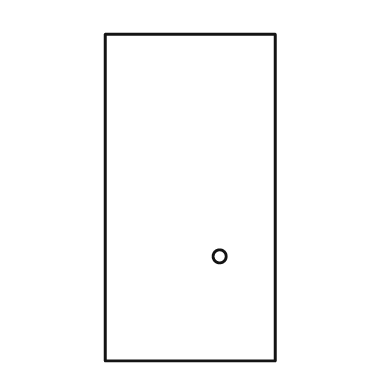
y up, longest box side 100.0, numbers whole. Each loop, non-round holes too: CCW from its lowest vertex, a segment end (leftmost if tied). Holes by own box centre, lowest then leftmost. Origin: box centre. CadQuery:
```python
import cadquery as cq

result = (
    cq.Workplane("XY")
    .moveTo(-26.0, -50.0)
    .lineTo(26.0, -50.0)
    .lineTo(26.0, 50.0)
    .lineTo(-26.0, 50.0)
    .close()
    .moveTo(9.0, -18.0)
    .circle(2.0)
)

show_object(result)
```